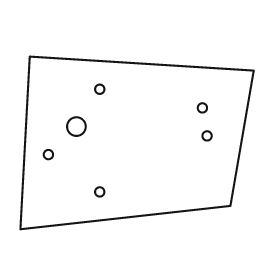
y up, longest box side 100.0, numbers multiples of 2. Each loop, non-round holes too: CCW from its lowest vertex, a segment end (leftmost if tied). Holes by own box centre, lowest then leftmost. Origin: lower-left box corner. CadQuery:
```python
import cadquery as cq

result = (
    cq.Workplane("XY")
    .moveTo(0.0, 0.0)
    .lineTo(90.0, 10.0)
    .lineTo(100.0, 68.0)
    .lineTo(4.0, 74.0)
    .close()
    .moveTo(34.0, 16.0)
    .circle(2.0)
    .moveTo(12.0, 32.0)
    .circle(2.0)
    .moveTo(80.0, 40.0)
    .circle(2.0)
    .moveTo(24.0, 44.0)
    .circle(4.0)
    .moveTo(78.0, 52.0)
    .circle(2.0)
    .moveTo(34.0, 60.0)
    .circle(2.0)
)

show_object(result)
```